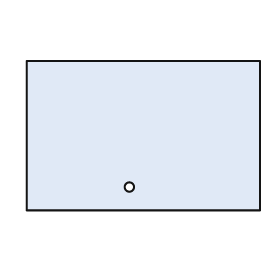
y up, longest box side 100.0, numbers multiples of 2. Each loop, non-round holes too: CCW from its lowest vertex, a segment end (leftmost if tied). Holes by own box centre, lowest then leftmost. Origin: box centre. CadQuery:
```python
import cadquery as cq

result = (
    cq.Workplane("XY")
    .moveTo(-50.0, -32.0)
    .lineTo(50.0, -32.0)
    .lineTo(50.0, 32.0)
    .lineTo(-50.0, 32.0)
    .close()
    .moveTo(-6.0, -22.0)
    .circle(2.0)
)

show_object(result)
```